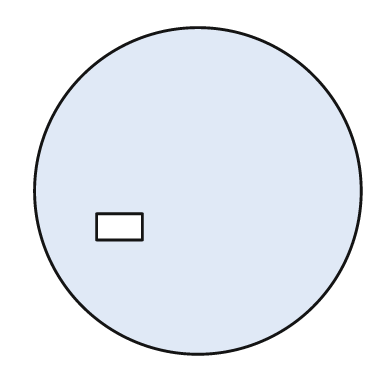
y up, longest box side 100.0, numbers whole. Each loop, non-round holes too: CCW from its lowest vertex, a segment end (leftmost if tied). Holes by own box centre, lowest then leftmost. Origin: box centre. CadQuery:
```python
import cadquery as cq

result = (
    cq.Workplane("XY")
    .moveTo(0.0, 0.0)
    .circle(50.0)
    .moveTo(-31.0, -15.0)
    .lineTo(-17.0, -15.0)
    .lineTo(-17.0, -7.0)
    .lineTo(-31.0, -7.0)
    .close()
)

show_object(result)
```